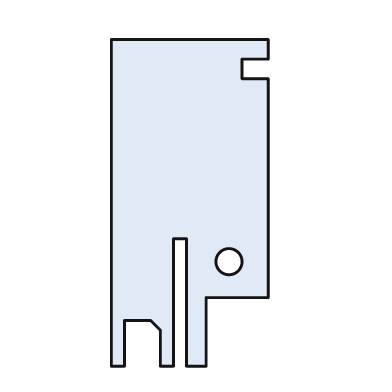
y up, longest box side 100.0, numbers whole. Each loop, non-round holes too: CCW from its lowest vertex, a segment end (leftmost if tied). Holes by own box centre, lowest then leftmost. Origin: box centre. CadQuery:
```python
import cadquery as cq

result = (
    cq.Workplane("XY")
    .moveTo(-24.0, -50.0)
    .lineTo(-20.0, -50.0)
    .lineTo(-20.0, -36.0)
    .lineTo(-12.0, -36.0)
    .lineTo(-9.0, -39.0)
    .lineTo(-9.0, -50.0)
    .lineTo(-5.0, -50.0)
    .lineTo(-5.0, -11.0)
    .lineTo(-1.0, -11.0)
    .lineTo(-1.0, -50.0)
    .lineTo(5.0, -50.0)
    .lineTo(5.0, -29.0)
    .lineTo(24.0, -29.0)
    .lineTo(24.0, 38.0)
    .lineTo(16.0, 38.0)
    .lineTo(16.0, 44.0)
    .lineTo(24.0, 44.0)
    .lineTo(24.0, 50.0)
    .lineTo(-24.0, 50.0)
    .close()
    .moveTo(12.0, -18.0)
    .circle(4.0)
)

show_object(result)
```